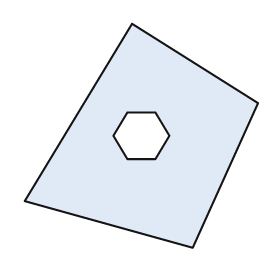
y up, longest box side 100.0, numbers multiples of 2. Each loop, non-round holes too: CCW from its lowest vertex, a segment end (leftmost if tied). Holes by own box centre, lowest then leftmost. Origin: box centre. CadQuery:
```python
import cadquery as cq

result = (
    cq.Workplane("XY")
    .moveTo(22.0, -48.0)
    .lineTo(50.0, 14.0)
    .lineTo(-4.0, 48.0)
    .lineTo(-50.0, -28.0)
    .close()
    .moveTo(-6.0, -10.0)
    .lineTo(6.0, -10.0)
    .lineTo(12.0, 0.0)
    .lineTo(6.0, 10.0)
    .lineTo(-6.0, 10.0)
    .lineTo(-12.0, 0.0)
    .close()
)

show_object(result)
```